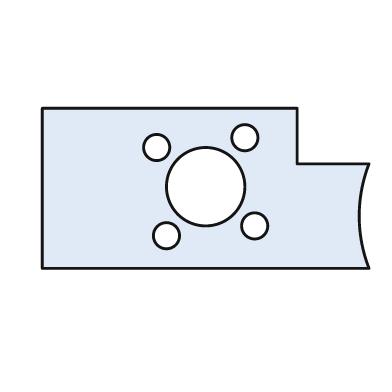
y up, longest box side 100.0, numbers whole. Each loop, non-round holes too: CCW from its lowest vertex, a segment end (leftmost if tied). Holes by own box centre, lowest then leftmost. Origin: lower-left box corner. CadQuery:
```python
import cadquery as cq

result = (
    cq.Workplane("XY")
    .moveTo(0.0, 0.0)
    .lineTo(100.0, 0.0)
    .threePointArc((97.0, 16.0), (100.0, 32.0))
    .lineTo(78.0, 32.0)
    .lineTo(78.0, 49.0)
    .lineTo(0.0, 49.0)
    .close()
    .moveTo(38.0, 10.0)
    .circle(4.0)
    .moveTo(65.0, 13.0)
    .circle(4.0)
    .moveTo(50.0, 25.0)
    .circle(12.0)
    .moveTo(35.0, 37.0)
    .circle(4.0)
    .moveTo(62.0, 40.0)
    .circle(4.0)
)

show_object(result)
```